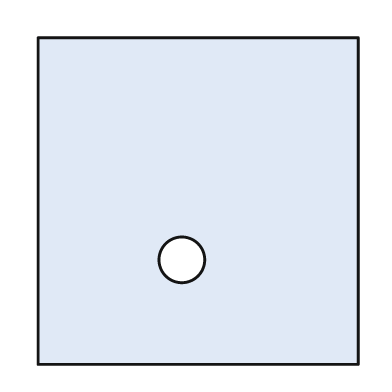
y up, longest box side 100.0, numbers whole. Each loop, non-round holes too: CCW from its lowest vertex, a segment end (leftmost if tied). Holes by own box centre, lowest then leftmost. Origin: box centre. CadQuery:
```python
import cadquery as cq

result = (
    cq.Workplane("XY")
    .moveTo(-49.0, -50.0)
    .lineTo(49.0, -50.0)
    .lineTo(49.0, 50.0)
    .lineTo(-49.0, 50.0)
    .close()
    .moveTo(-5.0, -18.0)
    .circle(7.0)
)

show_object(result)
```